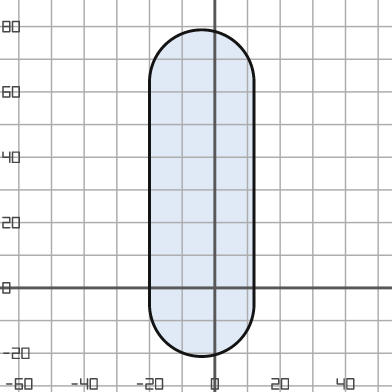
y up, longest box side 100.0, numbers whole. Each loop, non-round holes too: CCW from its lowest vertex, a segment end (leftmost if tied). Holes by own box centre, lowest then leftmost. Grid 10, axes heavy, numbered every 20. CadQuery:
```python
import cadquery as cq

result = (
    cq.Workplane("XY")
    .moveTo(-20.0, -5.0)
    .threePointArc((-4.0, -21.0), (12.0, -5.0))
    .lineTo(12.0, 63.0)
    .threePointArc((-4.0, 79.0), (-20.0, 63.0))
    .close()
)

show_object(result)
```